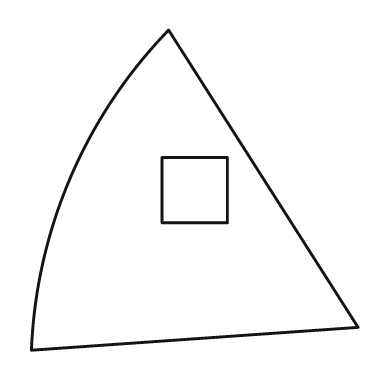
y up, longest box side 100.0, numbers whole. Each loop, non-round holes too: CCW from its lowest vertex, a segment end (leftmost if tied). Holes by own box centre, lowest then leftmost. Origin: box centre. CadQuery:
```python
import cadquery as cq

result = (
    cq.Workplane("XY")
    .moveTo(-50.0, -49.0)
    .lineTo(50.0, -42.0)
    .lineTo(-8.0, 49.0)
    .threePointArc((-38.0, 4.0), (-50.0, -49.0))
    .close()
    .moveTo(-10.0, -10.0)
    .lineTo(10.0, -10.0)
    .lineTo(10.0, 10.0)
    .lineTo(-10.0, 10.0)
    .close()
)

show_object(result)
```